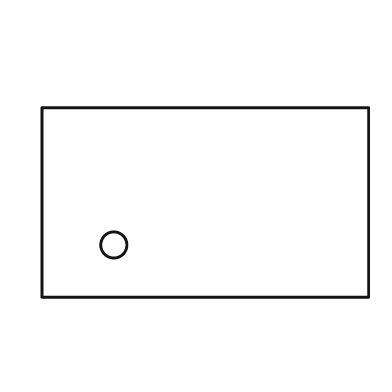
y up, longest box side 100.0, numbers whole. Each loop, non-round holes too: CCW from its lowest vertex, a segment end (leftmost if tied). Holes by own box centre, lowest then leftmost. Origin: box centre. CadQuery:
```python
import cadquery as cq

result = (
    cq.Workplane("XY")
    .moveTo(-50.0, -29.0)
    .lineTo(50.0, -29.0)
    .lineTo(50.0, 29.0)
    .lineTo(-50.0, 29.0)
    .close()
    .moveTo(-28.0, -13.0)
    .circle(4.0)
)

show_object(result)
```